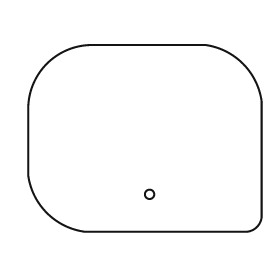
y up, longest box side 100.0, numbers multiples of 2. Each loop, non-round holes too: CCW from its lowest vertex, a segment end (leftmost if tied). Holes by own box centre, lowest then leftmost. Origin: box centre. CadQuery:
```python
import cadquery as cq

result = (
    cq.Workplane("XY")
    .moveTo(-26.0, -40.0)
    .lineTo(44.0, -40.0)
    .threePointArc((48.0, -38.0), (50.0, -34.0))
    .lineTo(50.0, 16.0)
    .threePointArc((42.0, 32.0), (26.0, 40.0))
    .lineTo(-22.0, 40.0)
    .threePointArc((-42.0, 32.0), (-50.0, 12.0))
    .lineTo(-50.0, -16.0)
    .threePointArc((-42.0, -32.0), (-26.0, -40.0))
    .close()
    .moveTo(2.0, -24.0)
    .circle(2.0)
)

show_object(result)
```